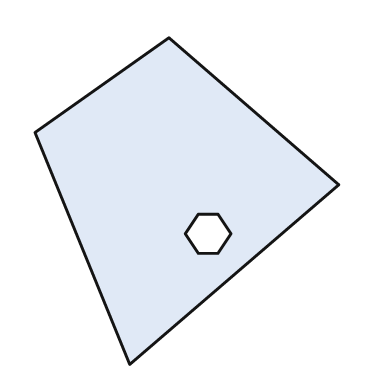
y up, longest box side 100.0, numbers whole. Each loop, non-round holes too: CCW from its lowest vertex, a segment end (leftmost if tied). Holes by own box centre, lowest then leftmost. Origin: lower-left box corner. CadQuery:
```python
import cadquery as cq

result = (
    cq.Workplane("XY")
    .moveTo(29.0, 0.0)
    .lineTo(93.0, 55.0)
    .lineTo(41.0, 100.0)
    .lineTo(0.0, 71.0)
    .close()
    .moveTo(50.0, 34.0)
    .lineTo(56.0, 34.0)
    .lineTo(60.0, 40.0)
    .lineTo(56.0, 46.0)
    .lineTo(50.0, 46.0)
    .lineTo(46.0, 40.0)
    .close()
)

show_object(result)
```